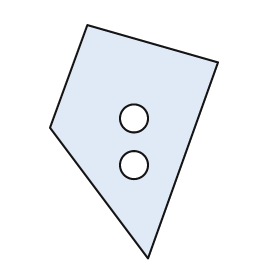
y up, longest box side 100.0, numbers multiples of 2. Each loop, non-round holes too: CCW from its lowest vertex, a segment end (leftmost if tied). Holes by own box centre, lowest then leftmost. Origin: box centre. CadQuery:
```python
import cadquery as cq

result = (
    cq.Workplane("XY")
    .moveTo(6.0, -50.0)
    .lineTo(36.0, 34.0)
    .lineTo(-20.0, 50.0)
    .lineTo(-36.0, 6.0)
    .close()
    .moveTo(0.0, -10.0)
    .circle(6.0)
    .moveTo(0.0, 10.0)
    .circle(6.0)
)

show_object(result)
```